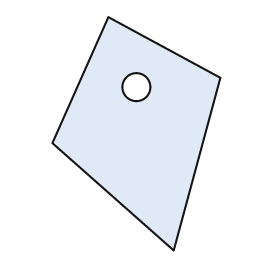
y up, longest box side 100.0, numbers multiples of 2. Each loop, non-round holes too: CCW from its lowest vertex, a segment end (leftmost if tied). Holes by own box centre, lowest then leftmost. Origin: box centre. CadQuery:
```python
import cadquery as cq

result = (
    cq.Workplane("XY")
    .moveTo(16.0, -50.0)
    .lineTo(36.0, 24.0)
    .lineTo(-12.0, 50.0)
    .lineTo(-36.0, -4.0)
    .close()
    .moveTo(0.0, 20.0)
    .circle(6.0)
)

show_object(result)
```